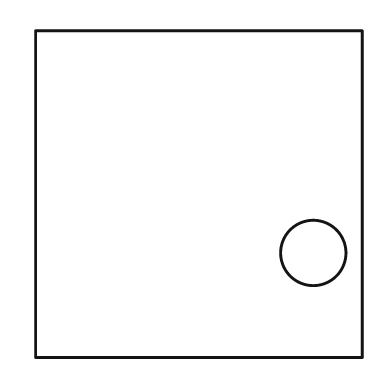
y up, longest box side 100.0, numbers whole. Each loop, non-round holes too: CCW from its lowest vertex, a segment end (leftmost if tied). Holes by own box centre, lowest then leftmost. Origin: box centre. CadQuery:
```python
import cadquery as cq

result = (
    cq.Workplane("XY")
    .moveTo(-50.0, -50.0)
    .lineTo(50.0, -50.0)
    .lineTo(50.0, 50.0)
    .lineTo(-50.0, 50.0)
    .close()
    .moveTo(35.0, -18.0)
    .circle(10.0)
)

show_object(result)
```